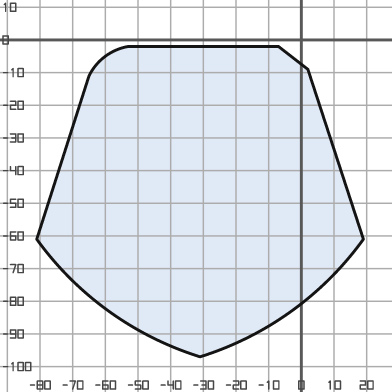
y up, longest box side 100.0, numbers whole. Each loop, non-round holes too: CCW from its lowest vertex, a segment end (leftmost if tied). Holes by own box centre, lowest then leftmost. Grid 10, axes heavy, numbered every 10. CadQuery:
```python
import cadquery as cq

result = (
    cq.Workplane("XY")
    .moveTo(-31.0, -97.0)
    .threePointArc((-3.0, -83.0), (19.0, -61.0))
    .lineTo(2.0, -9.0)
    .lineTo(-7.0, -2.0)
    .lineTo(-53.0, -2.0)
    .threePointArc((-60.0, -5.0), (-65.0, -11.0))
    .lineTo(-81.0, -61.0)
    .threePointArc((-59.0, -83.0), (-31.0, -97.0))
    .close()
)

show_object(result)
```